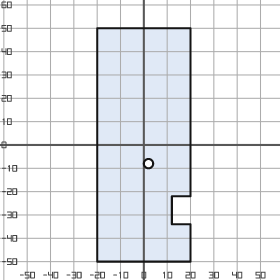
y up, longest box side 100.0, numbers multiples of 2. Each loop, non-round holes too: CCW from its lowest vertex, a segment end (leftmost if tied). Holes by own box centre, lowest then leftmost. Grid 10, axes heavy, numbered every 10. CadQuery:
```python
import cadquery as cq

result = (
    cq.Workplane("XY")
    .moveTo(-20.0, -50.0)
    .lineTo(20.0, -50.0)
    .lineTo(20.0, -34.0)
    .lineTo(12.0, -34.0)
    .lineTo(12.0, -22.0)
    .lineTo(20.0, -22.0)
    .lineTo(20.0, 50.0)
    .lineTo(-20.0, 50.0)
    .close()
    .moveTo(2.0, -8.0)
    .circle(2.0)
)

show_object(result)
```